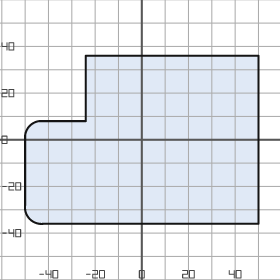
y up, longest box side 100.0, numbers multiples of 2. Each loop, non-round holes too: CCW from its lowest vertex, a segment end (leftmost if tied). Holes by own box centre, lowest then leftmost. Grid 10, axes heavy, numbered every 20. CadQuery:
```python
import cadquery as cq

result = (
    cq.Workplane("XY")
    .moveTo(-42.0, -36.0)
    .lineTo(50.0, -36.0)
    .lineTo(50.0, 36.0)
    .lineTo(-24.0, 36.0)
    .lineTo(-24.0, 8.0)
    .lineTo(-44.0, 8.0)
    .threePointArc((-48.0, 6.0), (-50.0, 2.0))
    .lineTo(-50.0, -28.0)
    .threePointArc((-48.0, -34.0), (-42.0, -36.0))
    .close()
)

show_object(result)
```